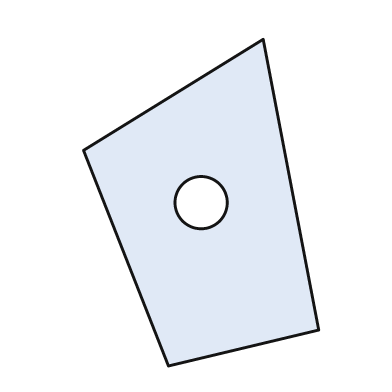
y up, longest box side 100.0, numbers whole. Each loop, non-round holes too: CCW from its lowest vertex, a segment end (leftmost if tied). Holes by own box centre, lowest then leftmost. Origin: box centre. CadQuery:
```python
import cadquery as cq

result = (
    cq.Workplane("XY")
    .moveTo(-10.0, -50.0)
    .lineTo(36.0, -39.0)
    .lineTo(19.0, 50.0)
    .lineTo(-36.0, 16.0)
    .close()
    .moveTo(0.0, 0.0)
    .circle(8.0)
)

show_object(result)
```